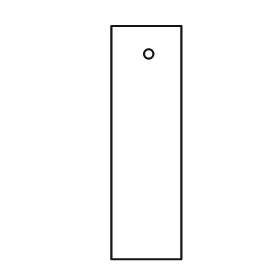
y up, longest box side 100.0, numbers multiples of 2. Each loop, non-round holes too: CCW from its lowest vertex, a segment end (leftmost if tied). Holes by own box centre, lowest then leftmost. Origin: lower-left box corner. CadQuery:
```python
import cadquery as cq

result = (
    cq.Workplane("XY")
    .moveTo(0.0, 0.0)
    .lineTo(30.0, 0.0)
    .lineTo(30.0, 100.0)
    .lineTo(0.0, 100.0)
    .close()
    .moveTo(16.0, 88.0)
    .circle(2.0)
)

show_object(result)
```